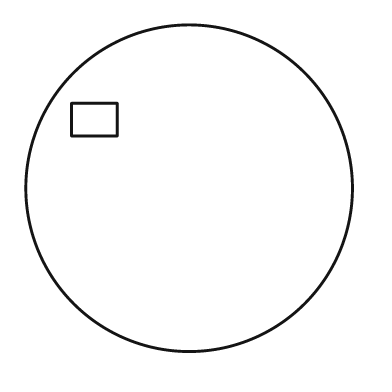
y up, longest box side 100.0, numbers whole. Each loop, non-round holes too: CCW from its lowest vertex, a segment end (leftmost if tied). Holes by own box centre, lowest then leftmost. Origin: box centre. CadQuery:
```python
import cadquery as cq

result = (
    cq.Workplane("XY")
    .moveTo(0.0, 0.0)
    .circle(50.0)
    .moveTo(-36.0, 16.0)
    .lineTo(-22.0, 16.0)
    .lineTo(-22.0, 26.0)
    .lineTo(-36.0, 26.0)
    .close()
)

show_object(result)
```